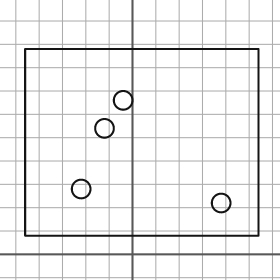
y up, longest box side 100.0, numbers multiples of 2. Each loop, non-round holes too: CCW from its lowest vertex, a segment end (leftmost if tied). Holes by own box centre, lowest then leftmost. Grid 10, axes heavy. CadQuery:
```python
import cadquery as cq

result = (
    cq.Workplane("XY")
    .moveTo(-46.0, 8.0)
    .lineTo(54.0, 8.0)
    .lineTo(54.0, 88.0)
    .lineTo(-46.0, 88.0)
    .close()
    .moveTo(38.0, 22.0)
    .circle(4.0)
    .moveTo(-22.0, 28.0)
    .circle(4.0)
    .moveTo(-12.0, 54.0)
    .circle(4.0)
    .moveTo(-4.0, 66.0)
    .circle(4.0)
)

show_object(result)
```